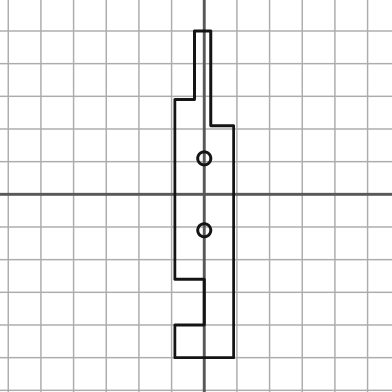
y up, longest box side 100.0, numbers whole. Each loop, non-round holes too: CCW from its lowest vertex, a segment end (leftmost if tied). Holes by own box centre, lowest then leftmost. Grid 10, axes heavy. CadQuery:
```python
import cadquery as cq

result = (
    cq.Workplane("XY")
    .moveTo(-9.0, -50.0)
    .lineTo(9.0, -50.0)
    .lineTo(9.0, 21.0)
    .lineTo(2.0, 21.0)
    .lineTo(2.0, 50.0)
    .lineTo(-3.0, 50.0)
    .lineTo(-3.0, 29.0)
    .lineTo(-9.0, 29.0)
    .lineTo(-9.0, -26.0)
    .lineTo(0.0, -26.0)
    .lineTo(0.0, -40.0)
    .lineTo(-9.0, -40.0)
    .close()
    .moveTo(0.0, -11.0)
    .circle(2.0)
    .moveTo(0.0, 11.0)
    .circle(2.0)
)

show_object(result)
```